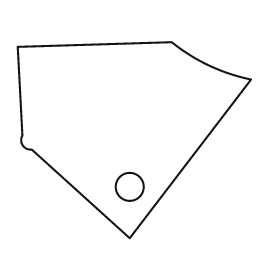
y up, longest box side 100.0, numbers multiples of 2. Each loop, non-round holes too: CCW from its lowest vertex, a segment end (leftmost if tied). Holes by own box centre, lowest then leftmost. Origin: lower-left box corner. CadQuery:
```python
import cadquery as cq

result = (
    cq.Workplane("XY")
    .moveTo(48.0, 0.0)
    .lineTo(100.0, 68.0)
    .threePointArc((82.0, 74.0), (66.0, 84.0))
    .lineTo(0.0, 82.0)
    .lineTo(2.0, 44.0)
    .threePointArc((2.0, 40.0), (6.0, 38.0))
    .close()
    .moveTo(48.0, 22.0)
    .circle(6.0)
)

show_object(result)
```